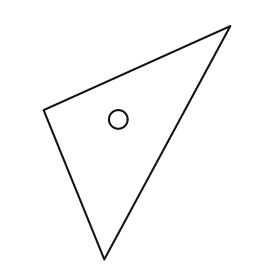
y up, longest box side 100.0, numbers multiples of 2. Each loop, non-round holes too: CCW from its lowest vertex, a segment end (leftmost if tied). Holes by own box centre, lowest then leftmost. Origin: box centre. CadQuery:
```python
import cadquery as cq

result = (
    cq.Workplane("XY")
    .moveTo(-14.0, -50.0)
    .lineTo(40.0, 50.0)
    .lineTo(-40.0, 14.0)
    .close()
    .moveTo(-8.0, 10.0)
    .circle(4.0)
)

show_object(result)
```